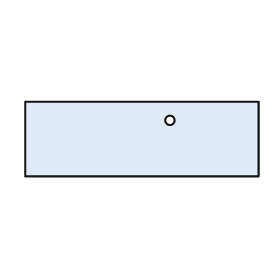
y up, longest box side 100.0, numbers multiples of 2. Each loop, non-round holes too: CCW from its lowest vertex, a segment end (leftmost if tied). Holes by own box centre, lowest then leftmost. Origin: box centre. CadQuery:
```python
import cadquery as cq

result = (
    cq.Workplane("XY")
    .moveTo(-50.0, -16.0)
    .lineTo(50.0, -16.0)
    .lineTo(50.0, 16.0)
    .lineTo(-50.0, 16.0)
    .close()
    .moveTo(12.0, 8.0)
    .circle(2.0)
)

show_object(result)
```